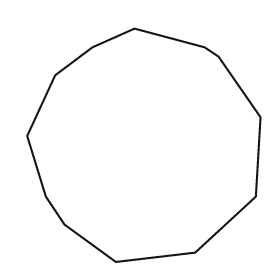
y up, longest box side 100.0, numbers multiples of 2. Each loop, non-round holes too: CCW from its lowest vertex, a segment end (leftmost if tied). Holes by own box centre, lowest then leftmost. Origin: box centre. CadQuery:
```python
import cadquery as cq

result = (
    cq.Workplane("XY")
    .moveTo(-12.0, -50.0)
    .lineTo(22.0, -46.0)
    .lineTo(48.0, -22.0)
    .lineTo(50.0, 12.0)
    .lineTo(32.0, 38.0)
    .lineTo(26.0, 42.0)
    .lineTo(-4.0, 50.0)
    .lineTo(-22.0, 42.0)
    .lineTo(-38.0, 30.0)
    .lineTo(-50.0, 4.0)
    .lineTo(-42.0, -22.0)
    .lineTo(-34.0, -34.0)
    .close()
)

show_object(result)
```